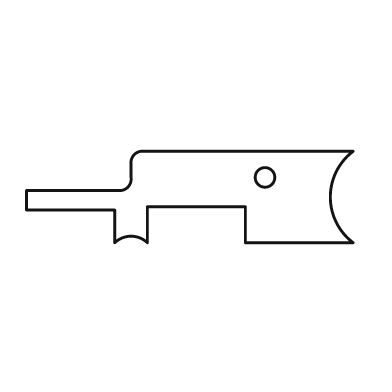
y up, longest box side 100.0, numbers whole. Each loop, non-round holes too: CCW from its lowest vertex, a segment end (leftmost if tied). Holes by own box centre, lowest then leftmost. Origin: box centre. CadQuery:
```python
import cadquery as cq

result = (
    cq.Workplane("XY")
    .moveTo(-23.0, -14.0)
    .threePointArc((-18.0, -12.0), (-13.0, -14.0))
    .lineTo(-13.0, -3.0)
    .lineTo(17.0, -3.0)
    .lineTo(17.0, -14.0)
    .lineTo(50.0, -14.0)
    .threePointArc((43.0, 0.0), (50.0, 14.0))
    .lineTo(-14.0, 14.0)
    .threePointArc((-17.0, 13.0), (-18.0, 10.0))
    .lineTo(-18.0, 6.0)
    .threePointArc((-19.0, 3.0), (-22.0, 2.0))
    .lineTo(-50.0, 2.0)
    .lineTo(-50.0, -4.0)
    .lineTo(-23.0, -4.0)
    .close()
    .moveTo(23.0, 6.0)
    .circle(3.0)
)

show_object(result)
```